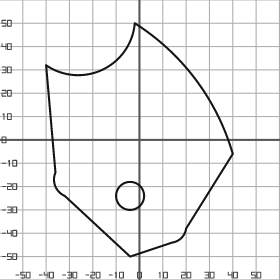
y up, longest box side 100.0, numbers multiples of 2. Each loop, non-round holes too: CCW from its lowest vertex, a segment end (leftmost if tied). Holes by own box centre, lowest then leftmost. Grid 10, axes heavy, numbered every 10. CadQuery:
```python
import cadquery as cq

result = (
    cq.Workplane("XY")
    .moveTo(-4.0, -50.0)
    .lineTo(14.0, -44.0)
    .threePointArc((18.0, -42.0), (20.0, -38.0))
    .lineTo(40.0, -6.0)
    .threePointArc((24.0, 26.0), (-2.0, 50.0))
    .threePointArc((-16.0, 30.0), (-40.0, 32.0))
    .lineTo(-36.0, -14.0)
    .threePointArc((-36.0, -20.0), (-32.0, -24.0))
    .close()
    .moveTo(-4.0, -24.0)
    .circle(6.0)
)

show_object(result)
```